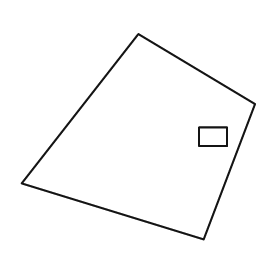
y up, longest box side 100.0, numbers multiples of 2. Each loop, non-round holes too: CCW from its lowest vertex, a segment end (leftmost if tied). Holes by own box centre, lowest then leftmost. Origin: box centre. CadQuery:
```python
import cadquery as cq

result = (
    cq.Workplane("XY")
    .moveTo(28.0, -44.0)
    .lineTo(50.0, 14.0)
    .lineTo(0.0, 44.0)
    .lineTo(-50.0, -20.0)
    .close()
    .moveTo(26.0, -4.0)
    .lineTo(38.0, -4.0)
    .lineTo(38.0, 4.0)
    .lineTo(26.0, 4.0)
    .close()
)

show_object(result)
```